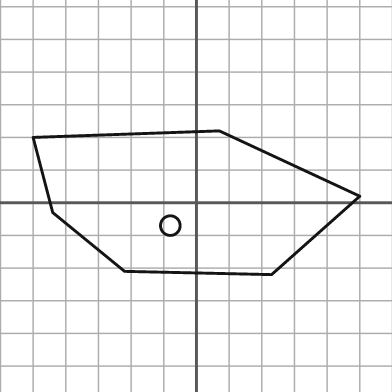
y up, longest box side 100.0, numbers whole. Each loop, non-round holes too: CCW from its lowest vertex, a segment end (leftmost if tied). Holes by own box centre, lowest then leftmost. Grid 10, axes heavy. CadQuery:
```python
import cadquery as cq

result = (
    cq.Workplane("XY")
    .moveTo(23.0, -22.0)
    .lineTo(50.0, 2.0)
    .lineTo(7.0, 22.0)
    .lineTo(-50.0, 20.0)
    .lineTo(-44.0, -3.0)
    .lineTo(-22.0, -21.0)
    .close()
    .moveTo(-8.0, -7.0)
    .circle(3.0)
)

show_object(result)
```